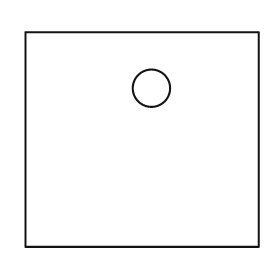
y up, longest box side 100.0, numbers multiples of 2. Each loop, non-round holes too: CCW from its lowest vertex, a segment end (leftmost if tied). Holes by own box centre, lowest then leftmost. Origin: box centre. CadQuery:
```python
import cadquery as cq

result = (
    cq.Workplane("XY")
    .moveTo(-50.0, -46.0)
    .lineTo(50.0, -46.0)
    .lineTo(50.0, 46.0)
    .lineTo(-50.0, 46.0)
    .close()
    .moveTo(4.0, 22.0)
    .circle(8.0)
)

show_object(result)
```